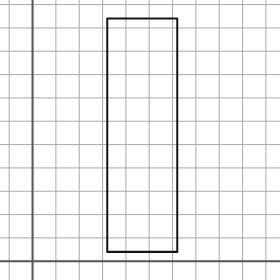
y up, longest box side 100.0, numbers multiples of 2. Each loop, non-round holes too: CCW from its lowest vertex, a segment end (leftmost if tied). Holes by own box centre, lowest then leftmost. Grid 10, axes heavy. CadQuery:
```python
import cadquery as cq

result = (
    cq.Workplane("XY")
    .moveTo(32.0, 4.0)
    .lineTo(62.0, 4.0)
    .lineTo(62.0, 104.0)
    .lineTo(32.0, 104.0)
    .close()
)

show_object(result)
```